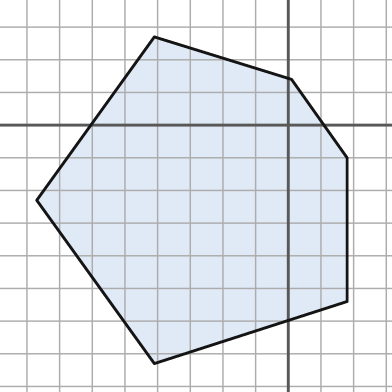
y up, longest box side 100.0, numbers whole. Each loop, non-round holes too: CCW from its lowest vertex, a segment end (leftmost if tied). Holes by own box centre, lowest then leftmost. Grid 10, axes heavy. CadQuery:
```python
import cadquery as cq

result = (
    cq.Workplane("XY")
    .moveTo(-41.0, -73.0)
    .lineTo(18.0, -54.0)
    .lineTo(18.0, -10.0)
    .lineTo(1.0, 14.0)
    .lineTo(-41.0, 27.0)
    .lineTo(-77.0, -23.0)
    .close()
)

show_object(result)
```